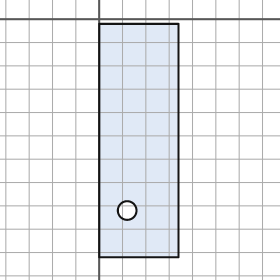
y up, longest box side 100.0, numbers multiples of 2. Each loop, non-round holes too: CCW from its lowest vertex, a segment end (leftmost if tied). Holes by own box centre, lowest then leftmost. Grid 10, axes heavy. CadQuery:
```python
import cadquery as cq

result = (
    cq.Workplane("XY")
    .moveTo(0.0, -102.0)
    .lineTo(34.0, -102.0)
    .lineTo(34.0, -2.0)
    .lineTo(0.0, -2.0)
    .close()
    .moveTo(12.0, -82.0)
    .circle(4.0)
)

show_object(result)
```